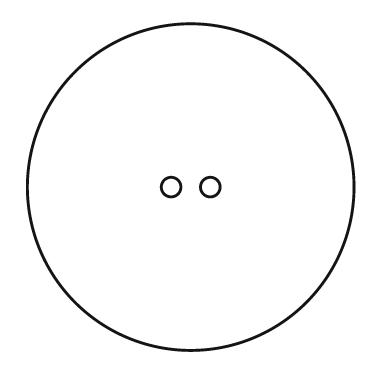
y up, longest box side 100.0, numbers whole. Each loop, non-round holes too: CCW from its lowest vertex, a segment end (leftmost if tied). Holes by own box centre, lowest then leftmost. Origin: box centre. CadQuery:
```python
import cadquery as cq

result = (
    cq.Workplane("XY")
    .moveTo(0.0, 0.0)
    .circle(50.0)
    .moveTo(-6.0, 0.0)
    .circle(3.0)
    .moveTo(6.0, 0.0)
    .circle(3.0)
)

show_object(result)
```